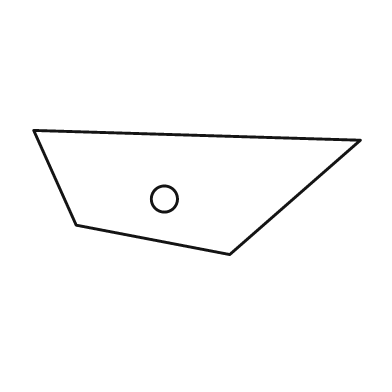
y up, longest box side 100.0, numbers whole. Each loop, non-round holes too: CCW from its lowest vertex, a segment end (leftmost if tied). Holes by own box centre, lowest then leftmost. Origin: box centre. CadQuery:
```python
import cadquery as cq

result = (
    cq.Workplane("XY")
    .moveTo(10.0, -19.0)
    .lineTo(50.0, 16.0)
    .lineTo(-50.0, 19.0)
    .lineTo(-37.0, -10.0)
    .close()
    .moveTo(-10.0, -2.0)
    .circle(4.0)
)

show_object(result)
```